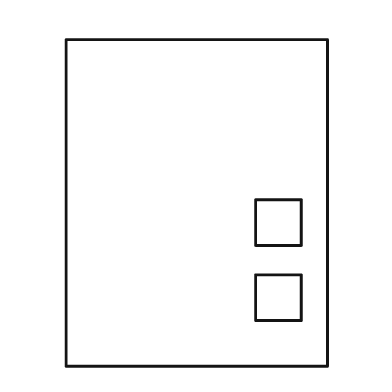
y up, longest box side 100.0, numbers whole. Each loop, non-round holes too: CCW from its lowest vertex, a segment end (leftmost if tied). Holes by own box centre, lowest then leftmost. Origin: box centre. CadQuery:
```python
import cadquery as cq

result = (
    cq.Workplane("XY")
    .moveTo(-40.0, -50.0)
    .lineTo(40.0, -50.0)
    .lineTo(40.0, 50.0)
    .lineTo(-40.0, 50.0)
    .close()
    .moveTo(18.0, -36.0)
    .lineTo(32.0, -36.0)
    .lineTo(32.0, -22.0)
    .lineTo(18.0, -22.0)
    .close()
    .moveTo(18.0, -13.0)
    .lineTo(32.0, -13.0)
    .lineTo(32.0, 1.0)
    .lineTo(18.0, 1.0)
    .close()
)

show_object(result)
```